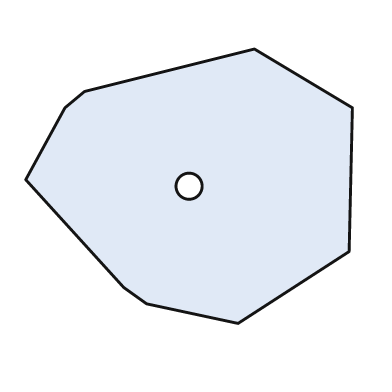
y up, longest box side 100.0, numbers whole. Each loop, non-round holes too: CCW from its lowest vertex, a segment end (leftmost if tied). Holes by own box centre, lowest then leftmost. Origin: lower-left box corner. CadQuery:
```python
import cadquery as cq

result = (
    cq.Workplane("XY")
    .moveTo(65.0, 0.0)
    .lineTo(99.0, 22.0)
    .lineTo(100.0, 66.0)
    .lineTo(70.0, 84.0)
    .lineTo(18.0, 71.0)
    .lineTo(12.0, 66.0)
    .lineTo(0.0, 44.0)
    .lineTo(30.0, 11.0)
    .lineTo(37.0, 6.0)
    .close()
    .moveTo(50.0, 42.0)
    .circle(4.0)
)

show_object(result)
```